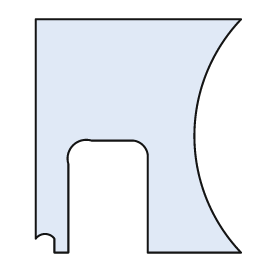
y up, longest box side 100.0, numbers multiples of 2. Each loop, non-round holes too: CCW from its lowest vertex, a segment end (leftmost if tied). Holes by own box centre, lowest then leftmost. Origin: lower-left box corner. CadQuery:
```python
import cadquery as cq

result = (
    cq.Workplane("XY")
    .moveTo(8.0, 0.0)
    .lineTo(14.0, 0.0)
    .lineTo(14.0, 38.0)
    .threePointArc((16.0, 46.0), (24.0, 48.0))
    .lineTo(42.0, 48.0)
    .threePointArc((46.0, 46.0), (48.0, 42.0))
    .lineTo(48.0, 0.0)
    .lineTo(88.0, 0.0)
    .threePointArc((68.0, 50.0), (88.0, 100.0))
    .lineTo(0.0, 100.0)
    .lineTo(0.0, 6.0)
    .threePointArc((4.0, 8.0), (8.0, 6.0))
    .close()
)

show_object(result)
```